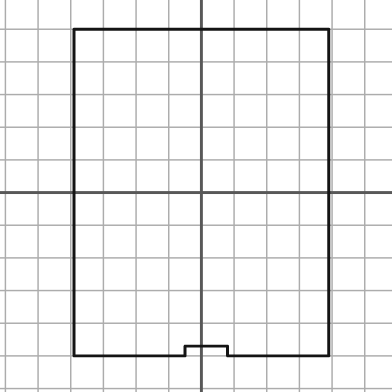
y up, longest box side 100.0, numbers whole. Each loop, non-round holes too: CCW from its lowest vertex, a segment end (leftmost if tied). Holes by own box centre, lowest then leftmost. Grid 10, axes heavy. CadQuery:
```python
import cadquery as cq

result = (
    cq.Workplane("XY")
    .moveTo(-39.0, -50.0)
    .lineTo(-5.0, -50.0)
    .lineTo(-5.0, -47.0)
    .lineTo(8.0, -47.0)
    .lineTo(8.0, -50.0)
    .lineTo(39.0, -50.0)
    .lineTo(39.0, 50.0)
    .lineTo(-39.0, 50.0)
    .close()
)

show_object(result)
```